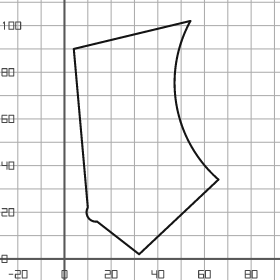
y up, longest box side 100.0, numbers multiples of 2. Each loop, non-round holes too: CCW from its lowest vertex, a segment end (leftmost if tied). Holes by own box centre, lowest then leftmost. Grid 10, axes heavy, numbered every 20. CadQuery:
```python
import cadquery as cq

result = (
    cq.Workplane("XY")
    .moveTo(32.0, 2.0)
    .lineTo(66.0, 34.0)
    .threePointArc((48.0, 66.0), (54.0, 102.0))
    .lineTo(4.0, 90.0)
    .lineTo(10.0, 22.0)
    .threePointArc((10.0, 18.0), (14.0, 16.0))
    .close()
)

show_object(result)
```